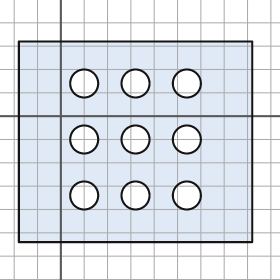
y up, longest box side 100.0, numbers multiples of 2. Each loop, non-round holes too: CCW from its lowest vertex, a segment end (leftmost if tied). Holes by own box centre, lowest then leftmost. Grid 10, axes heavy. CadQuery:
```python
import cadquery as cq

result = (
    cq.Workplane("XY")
    .moveTo(-18.0, -54.0)
    .lineTo(82.0, -54.0)
    .lineTo(82.0, 32.0)
    .lineTo(-18.0, 32.0)
    .close()
    .moveTo(10.0, -34.0)
    .circle(6.0)
    .moveTo(32.0, -34.0)
    .circle(6.0)
    .moveTo(54.0, -34.0)
    .circle(6.0)
    .moveTo(10.0, -10.0)
    .circle(6.0)
    .moveTo(32.0, -10.0)
    .circle(6.0)
    .moveTo(54.0, -10.0)
    .circle(6.0)
    .moveTo(10.0, 14.0)
    .circle(6.0)
    .moveTo(32.0, 14.0)
    .circle(6.0)
    .moveTo(54.0, 14.0)
    .circle(6.0)
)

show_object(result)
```